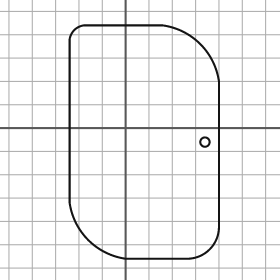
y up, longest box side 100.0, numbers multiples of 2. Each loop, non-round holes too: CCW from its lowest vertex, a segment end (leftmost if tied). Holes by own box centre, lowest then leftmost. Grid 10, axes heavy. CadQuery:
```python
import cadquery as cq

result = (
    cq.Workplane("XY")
    .moveTo(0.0, -56.0)
    .lineTo(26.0, -56.0)
    .threePointArc((36.0, -52.0), (40.0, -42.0))
    .lineTo(40.0, 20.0)
    .threePointArc((32.0, 36.0), (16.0, 44.0))
    .lineTo(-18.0, 44.0)
    .threePointArc((-22.0, 42.0), (-24.0, 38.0))
    .lineTo(-24.0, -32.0)
    .threePointArc((-16.0, -48.0), (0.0, -56.0))
    .close()
    .moveTo(34.0, -6.0)
    .circle(2.0)
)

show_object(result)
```